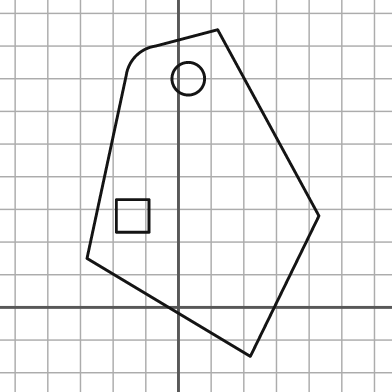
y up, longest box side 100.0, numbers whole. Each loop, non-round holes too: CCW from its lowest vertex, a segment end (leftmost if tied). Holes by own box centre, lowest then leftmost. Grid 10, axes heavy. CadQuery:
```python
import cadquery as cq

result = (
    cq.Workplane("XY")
    .moveTo(22.0, -15.0)
    .lineTo(43.0, 28.0)
    .lineTo(12.0, 85.0)
    .lineTo(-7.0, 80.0)
    .threePointArc((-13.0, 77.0), (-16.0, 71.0))
    .lineTo(-28.0, 15.0)
    .close()
    .moveTo(-19.0, 23.0)
    .lineTo(-9.0, 23.0)
    .lineTo(-9.0, 33.0)
    .lineTo(-19.0, 33.0)
    .close()
    .moveTo(3.0, 70.0)
    .circle(5.0)
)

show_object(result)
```